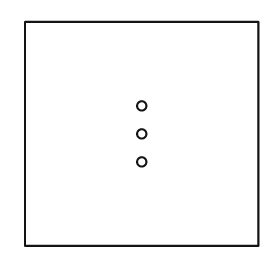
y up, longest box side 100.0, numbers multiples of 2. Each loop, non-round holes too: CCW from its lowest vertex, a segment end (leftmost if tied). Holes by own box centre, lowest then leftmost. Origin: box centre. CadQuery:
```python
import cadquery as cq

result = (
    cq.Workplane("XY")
    .moveTo(-50.0, -48.0)
    .lineTo(50.0, -48.0)
    .lineTo(50.0, 48.0)
    .lineTo(-50.0, 48.0)
    .close()
    .moveTo(0.0, -12.0)
    .circle(2.0)
    .moveTo(0.0, 0.0)
    .circle(2.0)
    .moveTo(0.0, 12.0)
    .circle(2.0)
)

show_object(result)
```